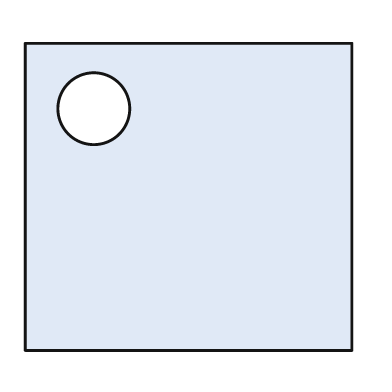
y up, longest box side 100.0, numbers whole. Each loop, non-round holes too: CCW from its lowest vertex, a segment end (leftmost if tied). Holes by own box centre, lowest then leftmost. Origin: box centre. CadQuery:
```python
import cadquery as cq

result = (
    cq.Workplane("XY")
    .moveTo(-50.0, -47.0)
    .lineTo(50.0, -47.0)
    .lineTo(50.0, 47.0)
    .lineTo(-50.0, 47.0)
    .close()
    .moveTo(-29.0, 27.0)
    .circle(11.0)
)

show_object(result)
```